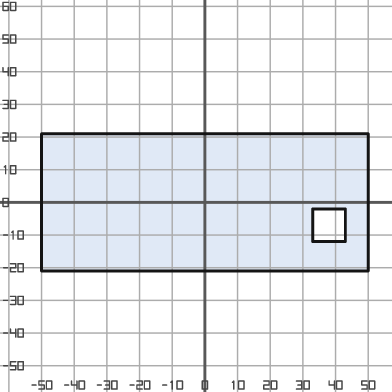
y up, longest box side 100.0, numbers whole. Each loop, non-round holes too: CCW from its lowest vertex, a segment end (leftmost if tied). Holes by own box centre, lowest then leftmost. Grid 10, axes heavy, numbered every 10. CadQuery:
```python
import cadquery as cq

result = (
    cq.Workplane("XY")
    .moveTo(-50.0, -21.0)
    .lineTo(50.0, -21.0)
    .lineTo(50.0, 21.0)
    .lineTo(-50.0, 21.0)
    .close()
    .moveTo(33.0, -12.0)
    .lineTo(43.0, -12.0)
    .lineTo(43.0, -2.0)
    .lineTo(33.0, -2.0)
    .close()
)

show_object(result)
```